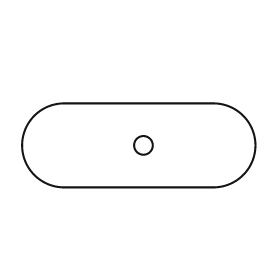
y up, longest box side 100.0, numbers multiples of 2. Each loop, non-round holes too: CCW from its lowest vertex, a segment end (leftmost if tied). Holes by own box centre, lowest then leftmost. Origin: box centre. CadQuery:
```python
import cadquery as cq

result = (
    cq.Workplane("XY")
    .moveTo(-32.0, -18.0)
    .lineTo(32.0, -18.0)
    .threePointArc((50.0, 0.0), (32.0, 18.0))
    .lineTo(-32.0, 18.0)
    .threePointArc((-50.0, 0.0), (-32.0, -18.0))
    .close()
    .moveTo(2.0, 0.0)
    .circle(4.0)
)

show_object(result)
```